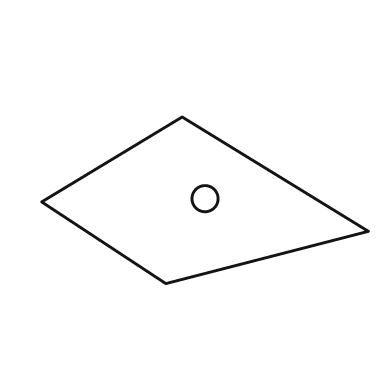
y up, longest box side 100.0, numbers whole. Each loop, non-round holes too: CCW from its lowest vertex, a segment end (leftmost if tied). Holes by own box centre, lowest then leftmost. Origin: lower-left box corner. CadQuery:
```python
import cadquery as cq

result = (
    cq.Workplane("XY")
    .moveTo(38.0, 0.0)
    .lineTo(100.0, 16.0)
    .lineTo(43.0, 51.0)
    .lineTo(0.0, 25.0)
    .close()
    .moveTo(50.0, 26.0)
    .circle(4.0)
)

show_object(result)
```